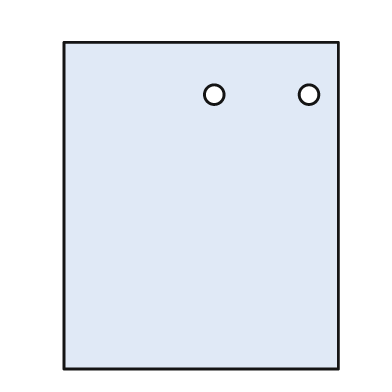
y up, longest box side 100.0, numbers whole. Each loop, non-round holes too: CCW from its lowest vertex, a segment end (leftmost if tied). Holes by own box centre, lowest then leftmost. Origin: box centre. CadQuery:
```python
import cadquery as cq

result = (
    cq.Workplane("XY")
    .moveTo(-42.0, -50.0)
    .lineTo(42.0, -50.0)
    .lineTo(42.0, 50.0)
    .lineTo(-42.0, 50.0)
    .close()
    .moveTo(4.0, 34.0)
    .circle(3.0)
    .moveTo(33.0, 34.0)
    .circle(3.0)
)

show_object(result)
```